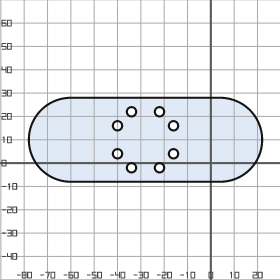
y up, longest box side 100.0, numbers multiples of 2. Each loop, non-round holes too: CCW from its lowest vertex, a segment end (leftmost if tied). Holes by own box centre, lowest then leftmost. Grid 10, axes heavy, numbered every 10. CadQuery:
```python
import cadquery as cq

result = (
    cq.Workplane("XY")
    .moveTo(-60.0, -8.0)
    .lineTo(4.0, -8.0)
    .threePointArc((22.0, 10.0), (4.0, 28.0))
    .lineTo(-60.0, 28.0)
    .threePointArc((-78.0, 10.0), (-60.0, -8.0))
    .close()
    .moveTo(-34.0, -2.0)
    .circle(2.0)
    .moveTo(-22.0, -2.0)
    .circle(2.0)
    .moveTo(-40.0, 4.0)
    .circle(2.0)
    .moveTo(-16.0, 4.0)
    .circle(2.0)
    .moveTo(-40.0, 16.0)
    .circle(2.0)
    .moveTo(-16.0, 16.0)
    .circle(2.0)
    .moveTo(-34.0, 22.0)
    .circle(2.0)
    .moveTo(-22.0, 22.0)
    .circle(2.0)
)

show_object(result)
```